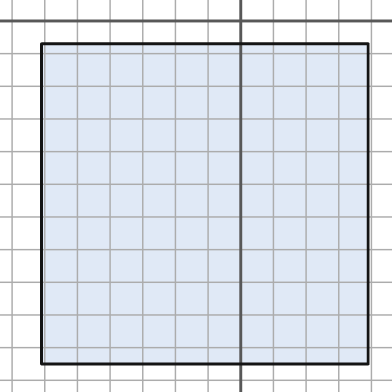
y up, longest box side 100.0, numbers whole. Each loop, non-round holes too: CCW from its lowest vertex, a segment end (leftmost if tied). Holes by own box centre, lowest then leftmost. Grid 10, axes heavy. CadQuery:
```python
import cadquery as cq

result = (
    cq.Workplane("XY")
    .moveTo(-61.0, -105.0)
    .lineTo(39.0, -105.0)
    .lineTo(39.0, -7.0)
    .lineTo(-61.0, -7.0)
    .close()
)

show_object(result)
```